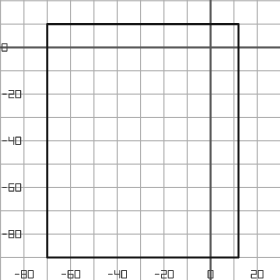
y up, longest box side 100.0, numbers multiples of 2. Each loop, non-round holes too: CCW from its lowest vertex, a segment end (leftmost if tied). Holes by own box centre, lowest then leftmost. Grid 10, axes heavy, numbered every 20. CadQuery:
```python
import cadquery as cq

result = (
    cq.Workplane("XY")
    .moveTo(-70.0, -90.0)
    .lineTo(12.0, -90.0)
    .lineTo(12.0, 10.0)
    .lineTo(-70.0, 10.0)
    .close()
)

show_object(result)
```